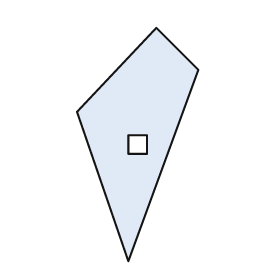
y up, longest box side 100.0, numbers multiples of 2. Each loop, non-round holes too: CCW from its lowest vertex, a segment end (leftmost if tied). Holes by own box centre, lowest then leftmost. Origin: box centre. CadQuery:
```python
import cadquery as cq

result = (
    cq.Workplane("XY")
    .moveTo(-4.0, -50.0)
    .lineTo(26.0, 32.0)
    .lineTo(8.0, 50.0)
    .lineTo(-26.0, 14.0)
    .close()
    .moveTo(-4.0, -4.0)
    .lineTo(4.0, -4.0)
    .lineTo(4.0, 4.0)
    .lineTo(-4.0, 4.0)
    .close()
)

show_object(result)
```